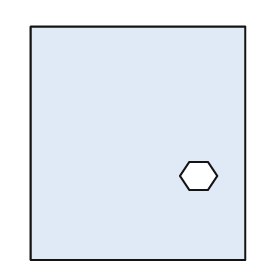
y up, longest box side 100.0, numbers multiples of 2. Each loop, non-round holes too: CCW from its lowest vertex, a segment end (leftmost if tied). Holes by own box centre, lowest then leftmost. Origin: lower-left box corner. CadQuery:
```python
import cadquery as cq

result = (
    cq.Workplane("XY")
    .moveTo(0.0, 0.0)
    .lineTo(92.0, 0.0)
    .lineTo(92.0, 100.0)
    .lineTo(0.0, 100.0)
    .close()
    .moveTo(68.0, 30.0)
    .lineTo(76.0, 30.0)
    .lineTo(80.0, 36.0)
    .lineTo(76.0, 42.0)
    .lineTo(68.0, 42.0)
    .lineTo(64.0, 36.0)
    .close()
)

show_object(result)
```